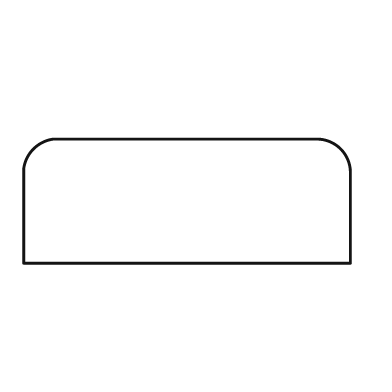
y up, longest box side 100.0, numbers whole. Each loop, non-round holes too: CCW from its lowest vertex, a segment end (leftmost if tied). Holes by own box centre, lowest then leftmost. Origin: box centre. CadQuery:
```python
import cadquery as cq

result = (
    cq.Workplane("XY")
    .moveTo(-50.0, -19.0)
    .lineTo(50.0, -19.0)
    .lineTo(50.0, 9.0)
    .threePointArc((47.0, 16.0), (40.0, 19.0))
    .lineTo(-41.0, 19.0)
    .threePointArc((-47.0, 16.0), (-50.0, 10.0))
    .close()
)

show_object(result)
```